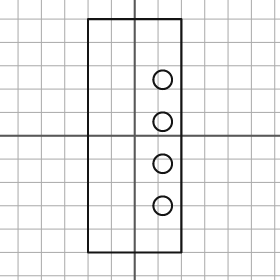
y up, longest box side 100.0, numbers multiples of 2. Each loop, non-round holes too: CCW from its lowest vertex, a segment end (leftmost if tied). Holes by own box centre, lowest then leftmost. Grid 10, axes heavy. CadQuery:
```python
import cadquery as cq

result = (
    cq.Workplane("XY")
    .moveTo(-20.0, -50.0)
    .lineTo(20.0, -50.0)
    .lineTo(20.0, 50.0)
    .lineTo(-20.0, 50.0)
    .close()
    .moveTo(12.0, -30.0)
    .circle(4.0)
    .moveTo(12.0, -12.0)
    .circle(4.0)
    .moveTo(12.0, 6.0)
    .circle(4.0)
    .moveTo(12.0, 24.0)
    .circle(4.0)
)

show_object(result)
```